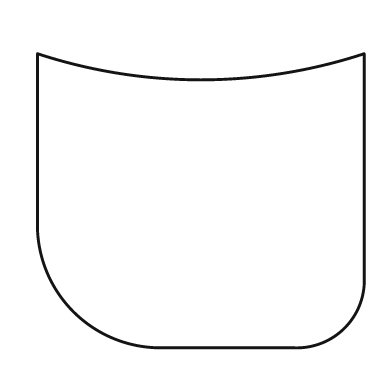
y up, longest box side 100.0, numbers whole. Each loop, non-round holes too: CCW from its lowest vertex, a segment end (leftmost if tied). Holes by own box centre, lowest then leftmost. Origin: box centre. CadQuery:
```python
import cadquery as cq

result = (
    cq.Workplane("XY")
    .moveTo(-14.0, -45.0)
    .lineTo(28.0, -45.0)
    .threePointArc((44.0, -39.0), (50.0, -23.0))
    .lineTo(50.0, 45.0)
    .threePointArc((0.0, 37.0), (-50.0, 45.0))
    .lineTo(-50.0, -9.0)
    .threePointArc((-39.0, -34.0), (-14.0, -45.0))
    .close()
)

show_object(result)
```